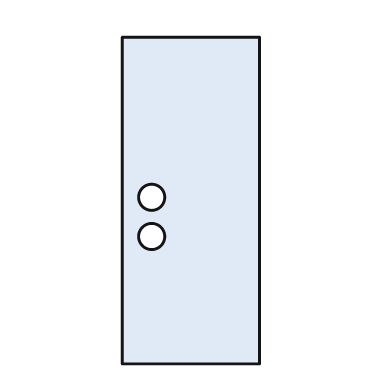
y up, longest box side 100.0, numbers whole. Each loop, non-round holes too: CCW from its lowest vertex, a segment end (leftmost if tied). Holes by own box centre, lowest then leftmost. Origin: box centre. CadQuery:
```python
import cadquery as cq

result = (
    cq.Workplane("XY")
    .moveTo(-21.0, -50.0)
    .lineTo(21.0, -50.0)
    .lineTo(21.0, 50.0)
    .lineTo(-21.0, 50.0)
    .close()
    .moveTo(-12.0, -11.0)
    .circle(4.0)
    .moveTo(-12.0, 1.0)
    .circle(4.0)
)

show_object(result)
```